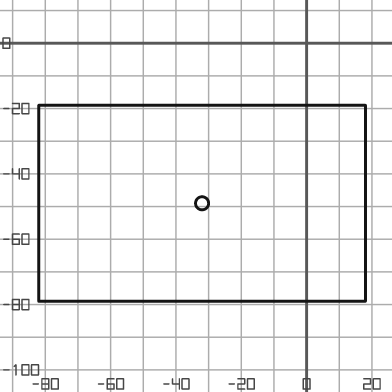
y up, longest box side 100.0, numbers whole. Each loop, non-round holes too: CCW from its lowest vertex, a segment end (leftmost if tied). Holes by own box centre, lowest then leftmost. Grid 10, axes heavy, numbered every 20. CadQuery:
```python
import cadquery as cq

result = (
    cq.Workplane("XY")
    .moveTo(-82.0, -79.0)
    .lineTo(18.0, -79.0)
    .lineTo(18.0, -19.0)
    .lineTo(-82.0, -19.0)
    .close()
    .moveTo(-32.0, -49.0)
    .circle(2.0)
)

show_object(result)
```